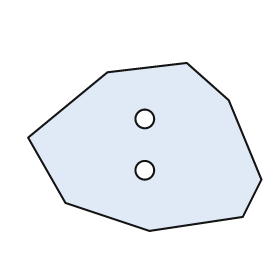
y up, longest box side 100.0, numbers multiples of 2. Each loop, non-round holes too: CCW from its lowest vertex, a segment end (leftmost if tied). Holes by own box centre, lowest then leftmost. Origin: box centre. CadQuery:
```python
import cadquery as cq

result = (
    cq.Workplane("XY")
    .moveTo(2.0, -36.0)
    .lineTo(42.0, -30.0)
    .lineTo(50.0, -14.0)
    .lineTo(36.0, 20.0)
    .lineTo(18.0, 36.0)
    .lineTo(-16.0, 32.0)
    .lineTo(-50.0, 4.0)
    .lineTo(-34.0, -24.0)
    .close()
    .moveTo(0.0, -10.0)
    .circle(4.0)
    .moveTo(0.0, 12.0)
    .circle(4.0)
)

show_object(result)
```